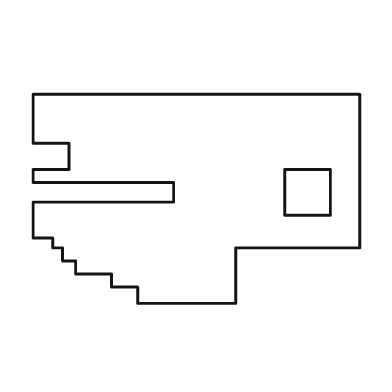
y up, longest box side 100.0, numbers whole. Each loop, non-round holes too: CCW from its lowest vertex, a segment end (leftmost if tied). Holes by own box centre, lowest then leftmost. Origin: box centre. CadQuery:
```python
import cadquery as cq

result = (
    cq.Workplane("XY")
    .moveTo(-18.0, -32.0)
    .lineTo(12.0, -32.0)
    .lineTo(12.0, -15.0)
    .lineTo(50.0, -15.0)
    .lineTo(50.0, 32.0)
    .lineTo(-50.0, 32.0)
    .lineTo(-50.0, 17.0)
    .lineTo(-39.0, 17.0)
    .lineTo(-39.0, 9.0)
    .lineTo(-50.0, 9.0)
    .lineTo(-50.0, 5.0)
    .lineTo(-7.0, 5.0)
    .lineTo(-7.0, -1.0)
    .lineTo(-50.0, -1.0)
    .lineTo(-50.0, -12.0)
    .lineTo(-44.0, -12.0)
    .lineTo(-44.0, -15.0)
    .lineTo(-41.0, -15.0)
    .lineTo(-41.0, -19.0)
    .lineTo(-37.0, -19.0)
    .lineTo(-37.0, -23.0)
    .lineTo(-26.0, -23.0)
    .lineTo(-26.0, -27.0)
    .lineTo(-18.0, -27.0)
    .close()
    .moveTo(27.0, -5.0)
    .lineTo(41.0, -5.0)
    .lineTo(41.0, 9.0)
    .lineTo(27.0, 9.0)
    .close()
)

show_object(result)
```